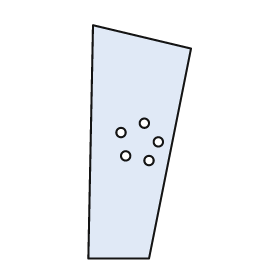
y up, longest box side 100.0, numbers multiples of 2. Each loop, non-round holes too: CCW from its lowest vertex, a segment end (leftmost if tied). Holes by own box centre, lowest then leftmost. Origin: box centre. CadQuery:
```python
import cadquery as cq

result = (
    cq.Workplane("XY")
    .moveTo(-22.0, -50.0)
    .lineTo(4.0, -50.0)
    .lineTo(22.0, 40.0)
    .lineTo(-20.0, 50.0)
    .close()
    .moveTo(4.0, -8.0)
    .circle(2.0)
    .moveTo(-6.0, -6.0)
    .circle(2.0)
    .moveTo(8.0, 0.0)
    .circle(2.0)
    .moveTo(-8.0, 4.0)
    .circle(2.0)
    .moveTo(2.0, 8.0)
    .circle(2.0)
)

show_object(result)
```